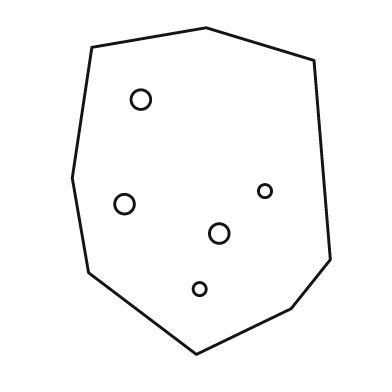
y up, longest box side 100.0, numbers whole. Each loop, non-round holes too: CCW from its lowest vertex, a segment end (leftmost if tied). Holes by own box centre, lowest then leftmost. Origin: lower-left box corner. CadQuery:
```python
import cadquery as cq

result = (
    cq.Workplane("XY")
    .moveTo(38.0, 0.0)
    .lineTo(67.0, 14.0)
    .lineTo(79.0, 29.0)
    .lineTo(74.0, 90.0)
    .lineTo(41.0, 100.0)
    .lineTo(6.0, 94.0)
    .lineTo(0.0, 54.0)
    .lineTo(5.0, 25.0)
    .close()
    .moveTo(39.0, 20.0)
    .circle(2.0)
    .moveTo(45.0, 37.0)
    .circle(3.0)
    .moveTo(16.0, 46.0)
    .circle(3.0)
    .moveTo(59.0, 50.0)
    .circle(2.0)
    .moveTo(21.0, 78.0)
    .circle(3.0)
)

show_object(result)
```